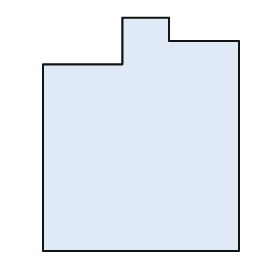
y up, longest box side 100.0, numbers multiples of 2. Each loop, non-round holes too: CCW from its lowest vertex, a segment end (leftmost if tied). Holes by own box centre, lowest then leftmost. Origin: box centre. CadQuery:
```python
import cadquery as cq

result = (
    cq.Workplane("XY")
    .moveTo(-42.0, -50.0)
    .lineTo(42.0, -50.0)
    .lineTo(42.0, 40.0)
    .lineTo(12.0, 40.0)
    .lineTo(12.0, 50.0)
    .lineTo(-8.0, 50.0)
    .lineTo(-8.0, 30.0)
    .lineTo(-42.0, 30.0)
    .close()
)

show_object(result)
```